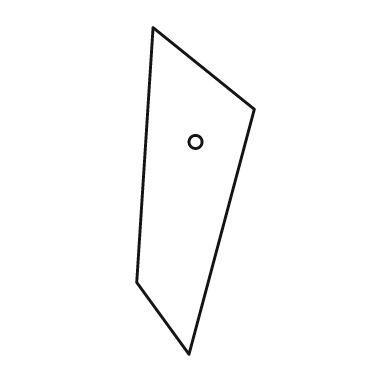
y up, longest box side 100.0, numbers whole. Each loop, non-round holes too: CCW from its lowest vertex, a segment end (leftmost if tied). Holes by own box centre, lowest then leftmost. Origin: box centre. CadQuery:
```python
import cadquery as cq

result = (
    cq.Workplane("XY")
    .moveTo(-2.0, -50.0)
    .lineTo(18.0, 25.0)
    .lineTo(-13.0, 50.0)
    .lineTo(-18.0, -28.0)
    .close()
    .moveTo(0.0, 15.0)
    .circle(2.0)
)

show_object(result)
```